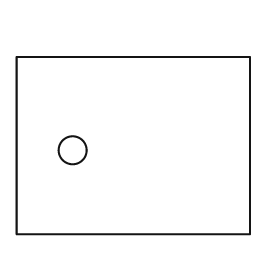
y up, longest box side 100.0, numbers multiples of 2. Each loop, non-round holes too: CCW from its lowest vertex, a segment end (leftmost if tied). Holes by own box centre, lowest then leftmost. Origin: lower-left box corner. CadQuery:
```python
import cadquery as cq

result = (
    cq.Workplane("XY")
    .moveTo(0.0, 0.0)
    .lineTo(100.0, 0.0)
    .lineTo(100.0, 76.0)
    .lineTo(0.0, 76.0)
    .close()
    .moveTo(24.0, 36.0)
    .circle(6.0)
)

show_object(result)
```